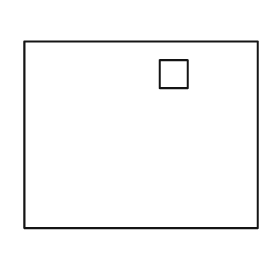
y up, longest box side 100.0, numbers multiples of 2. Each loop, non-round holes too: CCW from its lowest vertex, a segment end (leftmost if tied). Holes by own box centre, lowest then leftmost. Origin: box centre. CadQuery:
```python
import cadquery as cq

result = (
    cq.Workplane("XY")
    .moveTo(-50.0, -40.0)
    .lineTo(50.0, -40.0)
    .lineTo(50.0, 40.0)
    .lineTo(-50.0, 40.0)
    .close()
    .moveTo(8.0, 20.0)
    .lineTo(20.0, 20.0)
    .lineTo(20.0, 32.0)
    .lineTo(8.0, 32.0)
    .close()
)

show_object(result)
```